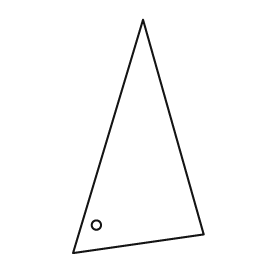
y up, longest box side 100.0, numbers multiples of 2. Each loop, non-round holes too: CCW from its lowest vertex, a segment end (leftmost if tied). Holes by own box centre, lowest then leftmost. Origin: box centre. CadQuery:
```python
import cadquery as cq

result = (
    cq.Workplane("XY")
    .moveTo(-28.0, -50.0)
    .lineTo(28.0, -42.0)
    .lineTo(2.0, 50.0)
    .close()
    .moveTo(-18.0, -38.0)
    .circle(2.0)
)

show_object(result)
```